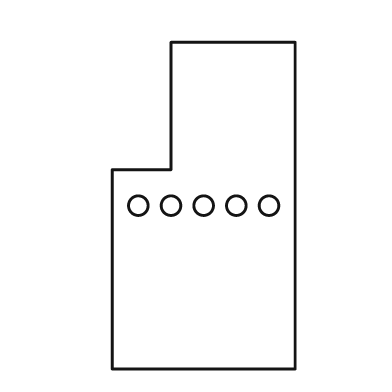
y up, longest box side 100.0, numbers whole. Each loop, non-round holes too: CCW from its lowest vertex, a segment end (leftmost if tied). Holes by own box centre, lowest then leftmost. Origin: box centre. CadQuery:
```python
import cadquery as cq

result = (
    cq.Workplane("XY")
    .moveTo(-28.0, -50.0)
    .lineTo(28.0, -50.0)
    .lineTo(28.0, 50.0)
    .lineTo(-10.0, 50.0)
    .lineTo(-10.0, 11.0)
    .lineTo(-28.0, 11.0)
    .close()
    .moveTo(-20.0, 0.0)
    .circle(3.0)
    .moveTo(-10.0, 0.0)
    .circle(3.0)
    .moveTo(0.0, 0.0)
    .circle(3.0)
    .moveTo(10.0, 0.0)
    .circle(3.0)
    .moveTo(20.0, 0.0)
    .circle(3.0)
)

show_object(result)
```